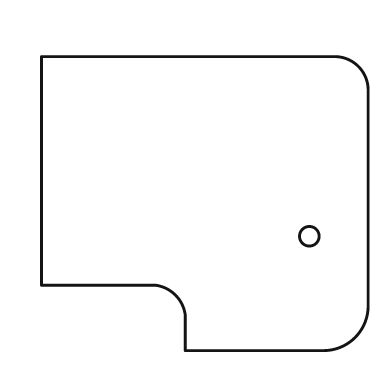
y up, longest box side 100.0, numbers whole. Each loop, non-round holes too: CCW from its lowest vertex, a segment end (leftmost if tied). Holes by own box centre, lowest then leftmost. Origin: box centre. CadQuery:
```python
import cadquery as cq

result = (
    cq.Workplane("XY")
    .moveTo(-6.0, -45.0)
    .lineTo(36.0, -45.0)
    .threePointArc((46.0, -41.0), (50.0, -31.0))
    .lineTo(50.0, 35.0)
    .threePointArc((47.0, 42.0), (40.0, 45.0))
    .lineTo(-50.0, 45.0)
    .lineTo(-50.0, -25.0)
    .lineTo(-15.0, -25.0)
    .threePointArc((-9.0, -28.0), (-6.0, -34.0))
    .close()
    .moveTo(32.0, -10.0)
    .circle(3.0)
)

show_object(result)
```